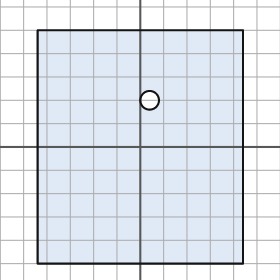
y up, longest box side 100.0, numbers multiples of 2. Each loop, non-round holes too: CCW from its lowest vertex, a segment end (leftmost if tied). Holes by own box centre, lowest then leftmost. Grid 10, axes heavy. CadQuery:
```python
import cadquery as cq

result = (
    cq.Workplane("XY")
    .moveTo(-44.0, -50.0)
    .lineTo(44.0, -50.0)
    .lineTo(44.0, 50.0)
    .lineTo(-44.0, 50.0)
    .close()
    .moveTo(4.0, 20.0)
    .circle(4.0)
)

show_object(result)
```